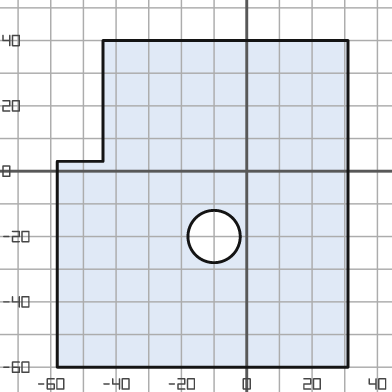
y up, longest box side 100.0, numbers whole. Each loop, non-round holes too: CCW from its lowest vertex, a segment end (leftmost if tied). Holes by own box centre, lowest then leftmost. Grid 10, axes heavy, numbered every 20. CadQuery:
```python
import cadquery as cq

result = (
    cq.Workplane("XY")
    .moveTo(-58.0, -60.0)
    .lineTo(31.0, -60.0)
    .lineTo(31.0, 40.0)
    .lineTo(-44.0, 40.0)
    .lineTo(-44.0, 3.0)
    .lineTo(-58.0, 3.0)
    .close()
    .moveTo(-10.0, -20.0)
    .circle(8.0)
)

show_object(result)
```